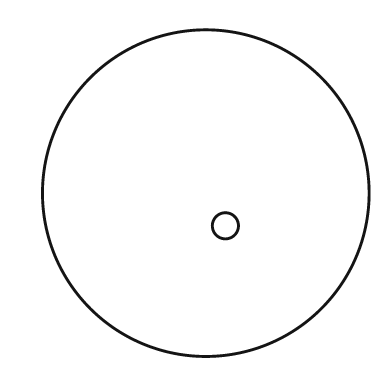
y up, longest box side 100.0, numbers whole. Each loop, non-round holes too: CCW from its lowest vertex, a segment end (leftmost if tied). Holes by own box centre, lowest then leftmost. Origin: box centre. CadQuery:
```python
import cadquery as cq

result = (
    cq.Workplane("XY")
    .moveTo(0.0, 0.0)
    .circle(50.0)
    .moveTo(6.0, -10.0)
    .circle(4.0)
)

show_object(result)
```